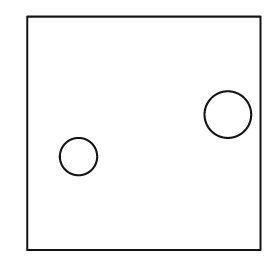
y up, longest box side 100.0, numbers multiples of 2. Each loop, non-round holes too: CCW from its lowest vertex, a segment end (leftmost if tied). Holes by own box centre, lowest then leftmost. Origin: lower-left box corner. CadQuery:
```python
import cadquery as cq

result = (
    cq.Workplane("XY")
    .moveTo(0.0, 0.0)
    .lineTo(100.0, 0.0)
    .lineTo(100.0, 100.0)
    .lineTo(0.0, 100.0)
    .close()
    .moveTo(22.0, 40.0)
    .circle(8.0)
    .moveTo(86.0, 58.0)
    .circle(10.0)
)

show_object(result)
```